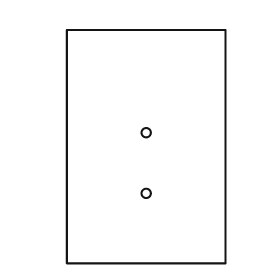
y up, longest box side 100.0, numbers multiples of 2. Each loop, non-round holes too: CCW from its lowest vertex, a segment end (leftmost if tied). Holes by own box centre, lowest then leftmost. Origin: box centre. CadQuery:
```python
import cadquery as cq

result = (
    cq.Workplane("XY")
    .moveTo(-34.0, -50.0)
    .lineTo(34.0, -50.0)
    .lineTo(34.0, 50.0)
    .lineTo(-34.0, 50.0)
    .close()
    .moveTo(0.0, -20.0)
    .circle(2.0)
    .moveTo(0.0, 6.0)
    .circle(2.0)
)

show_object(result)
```